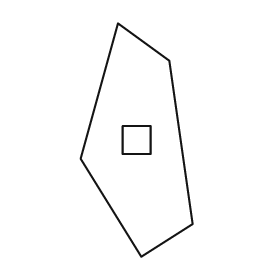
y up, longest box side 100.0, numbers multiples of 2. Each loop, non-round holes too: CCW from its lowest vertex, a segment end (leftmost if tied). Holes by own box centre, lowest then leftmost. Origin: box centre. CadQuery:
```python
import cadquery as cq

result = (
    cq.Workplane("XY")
    .moveTo(2.0, -50.0)
    .lineTo(24.0, -36.0)
    .lineTo(14.0, 34.0)
    .lineTo(-8.0, 50.0)
    .lineTo(-24.0, -8.0)
    .close()
    .moveTo(-6.0, -6.0)
    .lineTo(6.0, -6.0)
    .lineTo(6.0, 6.0)
    .lineTo(-6.0, 6.0)
    .close()
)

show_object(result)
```